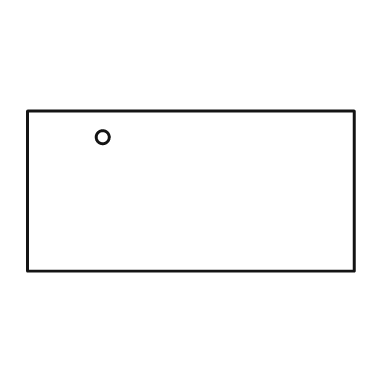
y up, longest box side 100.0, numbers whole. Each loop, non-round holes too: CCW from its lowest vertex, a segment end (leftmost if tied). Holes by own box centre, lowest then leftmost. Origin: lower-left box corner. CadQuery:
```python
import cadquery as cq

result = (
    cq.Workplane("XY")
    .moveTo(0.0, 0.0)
    .lineTo(100.0, 0.0)
    .lineTo(100.0, 49.0)
    .lineTo(0.0, 49.0)
    .close()
    .moveTo(23.0, 41.0)
    .circle(2.0)
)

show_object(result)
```